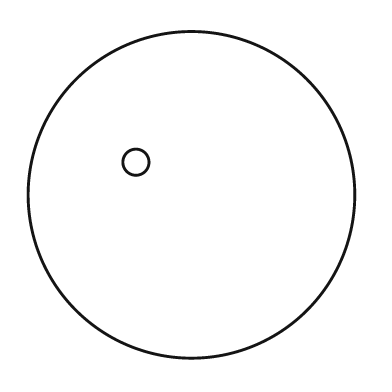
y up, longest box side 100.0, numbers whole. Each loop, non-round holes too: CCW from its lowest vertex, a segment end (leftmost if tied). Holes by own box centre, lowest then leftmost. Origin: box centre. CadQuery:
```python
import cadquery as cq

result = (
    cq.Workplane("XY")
    .moveTo(0.0, 0.0)
    .circle(50.0)
    .moveTo(-17.0, 10.0)
    .circle(4.0)
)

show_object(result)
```